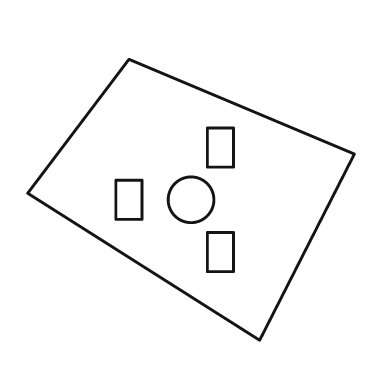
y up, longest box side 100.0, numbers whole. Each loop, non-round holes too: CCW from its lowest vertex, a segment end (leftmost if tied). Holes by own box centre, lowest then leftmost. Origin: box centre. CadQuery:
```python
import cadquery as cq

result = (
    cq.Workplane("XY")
    .moveTo(21.0, -43.0)
    .lineTo(50.0, 14.0)
    .lineTo(-19.0, 43.0)
    .lineTo(-50.0, 2.0)
    .close()
    .moveTo(5.0, -22.0)
    .lineTo(13.0, -22.0)
    .lineTo(13.0, -10.0)
    .lineTo(5.0, -10.0)
    .close()
    .moveTo(-23.0, -6.0)
    .lineTo(-15.0, -6.0)
    .lineTo(-15.0, 6.0)
    .lineTo(-23.0, 6.0)
    .close()
    .moveTo(0.0, 0.0)
    .circle(7.0)
    .moveTo(5.0, 10.0)
    .lineTo(13.0, 10.0)
    .lineTo(13.0, 22.0)
    .lineTo(5.0, 22.0)
    .close()
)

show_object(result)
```